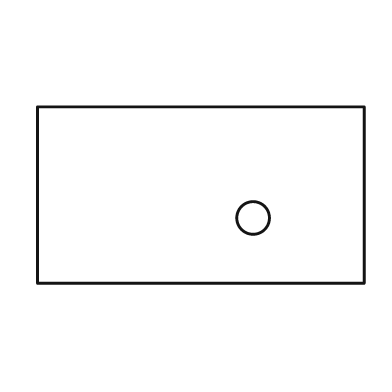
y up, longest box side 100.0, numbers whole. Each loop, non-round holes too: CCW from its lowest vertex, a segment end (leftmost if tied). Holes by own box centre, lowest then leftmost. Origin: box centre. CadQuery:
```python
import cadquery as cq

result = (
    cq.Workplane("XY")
    .moveTo(-50.0, -27.0)
    .lineTo(50.0, -27.0)
    .lineTo(50.0, 27.0)
    .lineTo(-50.0, 27.0)
    .close()
    .moveTo(16.0, -7.0)
    .circle(5.0)
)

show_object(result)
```